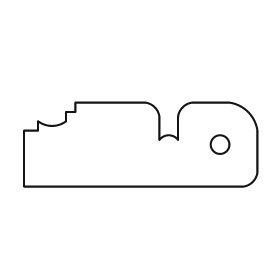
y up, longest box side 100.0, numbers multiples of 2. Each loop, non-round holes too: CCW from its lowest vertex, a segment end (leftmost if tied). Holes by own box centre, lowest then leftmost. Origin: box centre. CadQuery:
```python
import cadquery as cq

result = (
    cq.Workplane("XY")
    .moveTo(-50.0, -18.0)
    .lineTo(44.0, -18.0)
    .threePointArc((48.0, -16.0), (50.0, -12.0))
    .lineTo(50.0, 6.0)
    .threePointArc((46.0, 14.0), (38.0, 18.0))
    .lineTo(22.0, 18.0)
    .threePointArc((18.0, 16.0), (16.0, 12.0))
    .lineTo(16.0, 2.0)
    .threePointArc((12.0, 4.0), (8.0, 2.0))
    .lineTo(8.0, 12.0)
    .threePointArc((6.0, 16.0), (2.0, 18.0))
    .lineTo(-28.0, 18.0)
    .lineTo(-28.0, 14.0)
    .lineTo(-32.0, 14.0)
    .lineTo(-32.0, 10.0)
    .threePointArc((-38.0, 8.0), (-44.0, 10.0))
    .lineTo(-44.0, 6.0)
    .lineTo(-50.0, 6.0)
    .close()
    .moveTo(34.0, 0.0)
    .circle(4.0)
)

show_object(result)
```